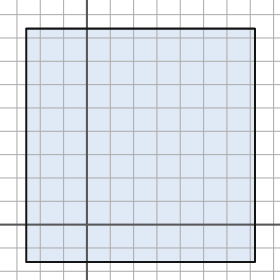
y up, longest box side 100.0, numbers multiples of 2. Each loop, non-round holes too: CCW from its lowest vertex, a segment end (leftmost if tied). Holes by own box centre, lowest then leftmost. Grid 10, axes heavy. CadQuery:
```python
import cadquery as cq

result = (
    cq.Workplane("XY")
    .moveTo(-26.0, -16.0)
    .lineTo(72.0, -16.0)
    .lineTo(72.0, 84.0)
    .lineTo(-26.0, 84.0)
    .close()
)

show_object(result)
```